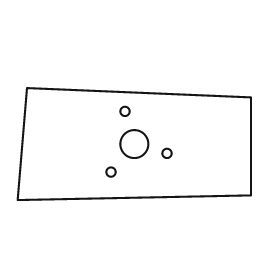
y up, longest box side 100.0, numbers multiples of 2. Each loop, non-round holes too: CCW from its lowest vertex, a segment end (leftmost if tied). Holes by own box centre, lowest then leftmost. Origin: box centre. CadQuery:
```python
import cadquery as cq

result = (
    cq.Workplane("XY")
    .moveTo(-50.0, -24.0)
    .lineTo(50.0, -22.0)
    .lineTo(50.0, 20.0)
    .lineTo(-46.0, 24.0)
    .close()
    .moveTo(-10.0, -12.0)
    .circle(2.0)
    .moveTo(14.0, -4.0)
    .circle(2.0)
    .moveTo(0.0, 0.0)
    .circle(6.0)
    .moveTo(-4.0, 14.0)
    .circle(2.0)
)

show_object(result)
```